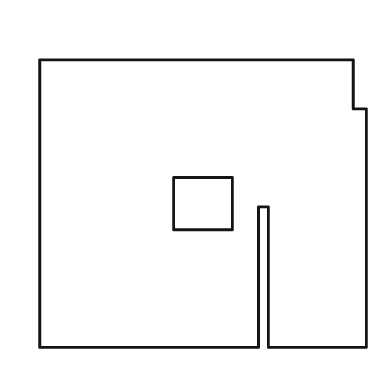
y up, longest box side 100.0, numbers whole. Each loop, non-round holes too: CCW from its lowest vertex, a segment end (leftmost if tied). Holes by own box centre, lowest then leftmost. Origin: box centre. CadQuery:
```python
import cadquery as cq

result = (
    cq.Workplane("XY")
    .moveTo(-50.0, -44.0)
    .lineTo(17.0, -44.0)
    .lineTo(17.0, -1.0)
    .lineTo(20.0, -1.0)
    .lineTo(20.0, -44.0)
    .lineTo(50.0, -44.0)
    .lineTo(50.0, 29.0)
    .lineTo(46.0, 29.0)
    .lineTo(46.0, 44.0)
    .lineTo(-50.0, 44.0)
    .close()
    .moveTo(-9.0, -8.0)
    .lineTo(9.0, -8.0)
    .lineTo(9.0, 8.0)
    .lineTo(-9.0, 8.0)
    .close()
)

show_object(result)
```